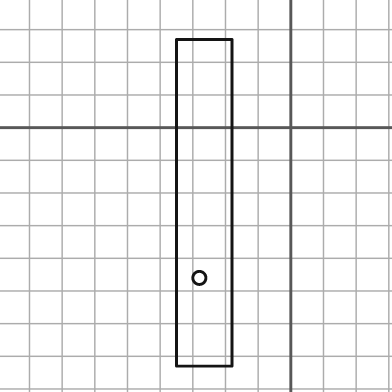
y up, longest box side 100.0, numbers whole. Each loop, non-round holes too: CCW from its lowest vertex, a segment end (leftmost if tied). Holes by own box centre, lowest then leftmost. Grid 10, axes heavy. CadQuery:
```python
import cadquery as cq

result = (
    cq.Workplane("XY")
    .moveTo(-35.0, -73.0)
    .lineTo(-18.0, -73.0)
    .lineTo(-18.0, 27.0)
    .lineTo(-35.0, 27.0)
    .close()
    .moveTo(-28.0, -46.0)
    .circle(2.0)
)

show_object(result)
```